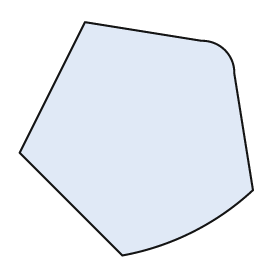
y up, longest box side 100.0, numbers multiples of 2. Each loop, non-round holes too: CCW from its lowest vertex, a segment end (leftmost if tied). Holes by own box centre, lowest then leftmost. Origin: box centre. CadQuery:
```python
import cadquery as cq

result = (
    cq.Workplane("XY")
    .moveTo(-6.0, -50.0)
    .threePointArc((24.0, -40.0), (50.0, -22.0))
    .lineTo(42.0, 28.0)
    .threePointArc((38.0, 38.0), (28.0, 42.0))
    .lineTo(-22.0, 50.0)
    .lineTo(-50.0, -6.0)
    .close()
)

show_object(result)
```